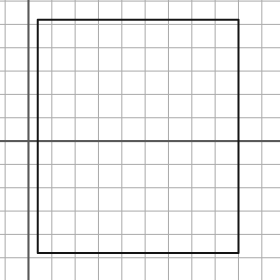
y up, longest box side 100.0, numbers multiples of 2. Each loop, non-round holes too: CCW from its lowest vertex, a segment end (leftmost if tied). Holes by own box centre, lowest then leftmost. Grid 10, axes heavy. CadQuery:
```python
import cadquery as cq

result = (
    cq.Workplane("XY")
    .moveTo(4.0, -48.0)
    .lineTo(90.0, -48.0)
    .lineTo(90.0, 52.0)
    .lineTo(4.0, 52.0)
    .close()
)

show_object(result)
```